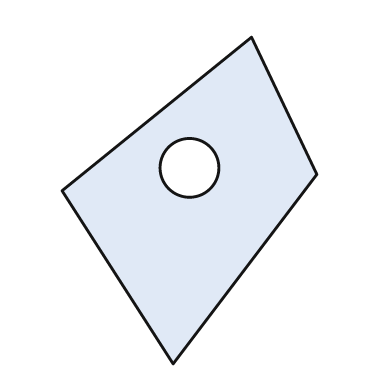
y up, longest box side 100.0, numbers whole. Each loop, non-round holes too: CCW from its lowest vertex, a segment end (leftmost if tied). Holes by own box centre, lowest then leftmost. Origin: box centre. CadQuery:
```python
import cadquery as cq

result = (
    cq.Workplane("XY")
    .moveTo(-5.0, -50.0)
    .lineTo(39.0, 8.0)
    .lineTo(19.0, 50.0)
    .lineTo(-39.0, 3.0)
    .close()
    .moveTo(0.0, 10.0)
    .circle(9.0)
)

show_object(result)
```